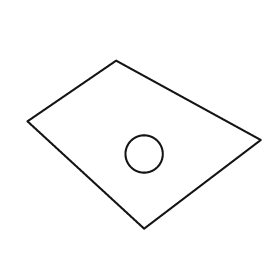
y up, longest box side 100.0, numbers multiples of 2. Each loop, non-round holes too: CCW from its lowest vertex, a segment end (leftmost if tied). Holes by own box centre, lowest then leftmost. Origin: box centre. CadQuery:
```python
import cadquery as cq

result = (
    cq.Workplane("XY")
    .moveTo(0.0, -36.0)
    .lineTo(50.0, 2.0)
    .lineTo(-12.0, 36.0)
    .lineTo(-50.0, 10.0)
    .close()
    .moveTo(0.0, -4.0)
    .circle(8.0)
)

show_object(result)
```